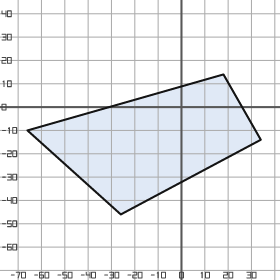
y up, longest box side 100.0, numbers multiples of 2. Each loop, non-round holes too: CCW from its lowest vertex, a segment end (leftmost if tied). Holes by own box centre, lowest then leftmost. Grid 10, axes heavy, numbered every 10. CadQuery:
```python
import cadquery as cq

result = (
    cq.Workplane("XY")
    .moveTo(-26.0, -46.0)
    .lineTo(34.0, -14.0)
    .lineTo(18.0, 14.0)
    .lineTo(-66.0, -10.0)
    .close()
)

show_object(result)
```